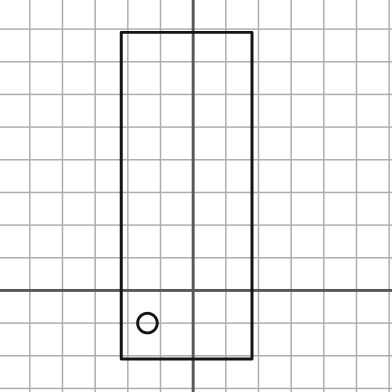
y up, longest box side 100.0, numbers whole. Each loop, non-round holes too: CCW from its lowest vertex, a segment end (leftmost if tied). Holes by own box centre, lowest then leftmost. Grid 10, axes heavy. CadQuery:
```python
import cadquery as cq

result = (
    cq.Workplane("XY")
    .moveTo(-22.0, -21.0)
    .lineTo(18.0, -21.0)
    .lineTo(18.0, 79.0)
    .lineTo(-22.0, 79.0)
    .close()
    .moveTo(-14.0, -10.0)
    .circle(3.0)
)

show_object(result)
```